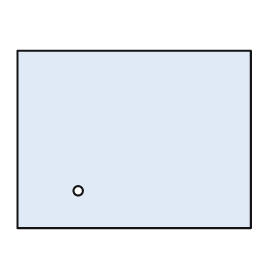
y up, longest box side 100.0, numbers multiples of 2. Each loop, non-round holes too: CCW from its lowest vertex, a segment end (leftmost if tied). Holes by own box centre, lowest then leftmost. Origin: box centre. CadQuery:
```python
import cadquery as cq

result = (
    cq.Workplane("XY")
    .moveTo(-50.0, -38.0)
    .lineTo(50.0, -38.0)
    .lineTo(50.0, 38.0)
    .lineTo(-50.0, 38.0)
    .close()
    .moveTo(-24.0, -22.0)
    .circle(2.0)
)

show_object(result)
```